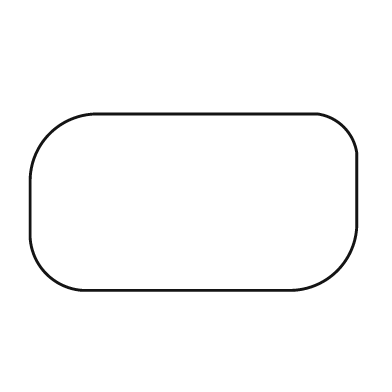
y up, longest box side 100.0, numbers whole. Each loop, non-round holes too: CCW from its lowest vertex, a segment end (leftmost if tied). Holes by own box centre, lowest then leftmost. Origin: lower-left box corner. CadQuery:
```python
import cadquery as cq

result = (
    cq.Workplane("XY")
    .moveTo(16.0, 0.0)
    .lineTo(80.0, 0.0)
    .threePointArc((94.0, 6.0), (100.0, 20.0))
    .lineTo(100.0, 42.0)
    .threePointArc((96.0, 50.0), (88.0, 54.0))
    .lineTo(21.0, 54.0)
    .threePointArc((6.0, 48.0), (0.0, 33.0))
    .lineTo(0.0, 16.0)
    .threePointArc((5.0, 5.0), (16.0, 0.0))
    .close()
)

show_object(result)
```